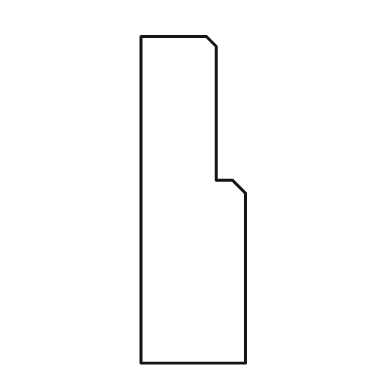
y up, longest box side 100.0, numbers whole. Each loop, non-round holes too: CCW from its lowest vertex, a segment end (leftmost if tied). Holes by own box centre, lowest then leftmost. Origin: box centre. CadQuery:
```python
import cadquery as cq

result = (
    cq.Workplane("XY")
    .moveTo(-16.0, -50.0)
    .lineTo(16.0, -50.0)
    .lineTo(16.0, 2.0)
    .lineTo(12.0, 6.0)
    .lineTo(7.0, 6.0)
    .lineTo(7.0, 47.0)
    .lineTo(4.0, 50.0)
    .lineTo(-16.0, 50.0)
    .close()
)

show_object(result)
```